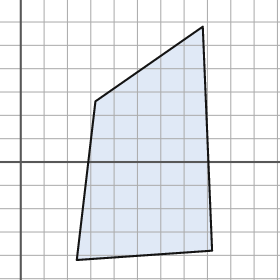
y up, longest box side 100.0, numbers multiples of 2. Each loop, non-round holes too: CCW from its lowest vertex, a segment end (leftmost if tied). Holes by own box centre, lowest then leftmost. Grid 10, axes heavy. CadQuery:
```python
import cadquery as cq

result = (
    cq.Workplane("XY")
    .moveTo(24.0, -42.0)
    .lineTo(82.0, -38.0)
    .lineTo(78.0, 58.0)
    .lineTo(32.0, 26.0)
    .close()
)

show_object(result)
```